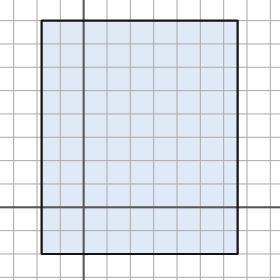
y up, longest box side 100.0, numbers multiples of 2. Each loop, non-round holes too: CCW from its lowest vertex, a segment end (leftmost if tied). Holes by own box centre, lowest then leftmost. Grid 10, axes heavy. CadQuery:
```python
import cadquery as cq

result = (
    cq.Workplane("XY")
    .moveTo(-18.0, -20.0)
    .lineTo(66.0, -20.0)
    .lineTo(66.0, 80.0)
    .lineTo(-18.0, 80.0)
    .close()
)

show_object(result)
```